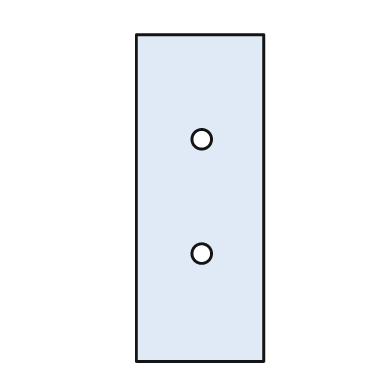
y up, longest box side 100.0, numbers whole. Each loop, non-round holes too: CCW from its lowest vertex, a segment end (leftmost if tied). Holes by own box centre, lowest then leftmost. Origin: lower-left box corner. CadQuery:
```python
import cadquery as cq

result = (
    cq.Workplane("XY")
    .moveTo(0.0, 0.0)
    .lineTo(39.0, 0.0)
    .lineTo(39.0, 100.0)
    .lineTo(0.0, 100.0)
    .close()
    .moveTo(20.0, 33.0)
    .circle(3.0)
    .moveTo(20.0, 68.0)
    .circle(3.0)
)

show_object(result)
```